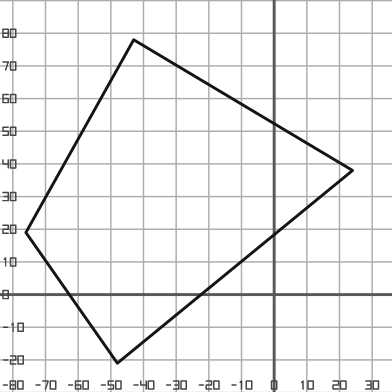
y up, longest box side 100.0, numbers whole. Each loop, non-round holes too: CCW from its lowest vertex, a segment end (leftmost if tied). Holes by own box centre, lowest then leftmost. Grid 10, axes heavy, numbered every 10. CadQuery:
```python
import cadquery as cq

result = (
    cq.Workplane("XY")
    .moveTo(-48.0, -21.0)
    .lineTo(24.0, 38.0)
    .lineTo(-43.0, 78.0)
    .lineTo(-76.0, 19.0)
    .close()
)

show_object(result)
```